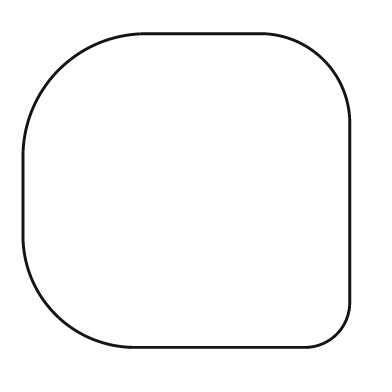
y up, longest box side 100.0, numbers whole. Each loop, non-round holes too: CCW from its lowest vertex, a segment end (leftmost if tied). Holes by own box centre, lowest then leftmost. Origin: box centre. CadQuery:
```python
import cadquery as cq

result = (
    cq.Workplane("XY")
    .moveTo(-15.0, -48.0)
    .lineTo(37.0, -48.0)
    .threePointArc((46.0, -44.0), (50.0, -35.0))
    .lineTo(50.0, 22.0)
    .threePointArc((42.0, 40.0), (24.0, 48.0))
    .lineTo(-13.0, 48.0)
    .threePointArc((-39.0, 37.0), (-50.0, 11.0))
    .lineTo(-50.0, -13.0)
    .threePointArc((-40.0, -38.0), (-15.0, -48.0))
    .close()
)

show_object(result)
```